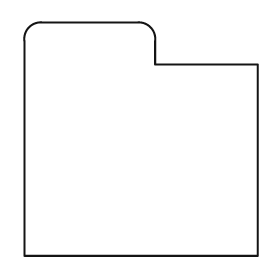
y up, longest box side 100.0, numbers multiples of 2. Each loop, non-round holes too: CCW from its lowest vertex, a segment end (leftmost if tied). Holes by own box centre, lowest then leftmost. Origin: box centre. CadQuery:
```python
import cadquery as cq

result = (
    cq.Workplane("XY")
    .moveTo(-50.0, -50.0)
    .lineTo(50.0, -50.0)
    .lineTo(50.0, 32.0)
    .lineTo(6.0, 32.0)
    .lineTo(6.0, 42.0)
    .threePointArc((4.0, 48.0), (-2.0, 50.0))
    .lineTo(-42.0, 50.0)
    .threePointArc((-48.0, 48.0), (-50.0, 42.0))
    .close()
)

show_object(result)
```